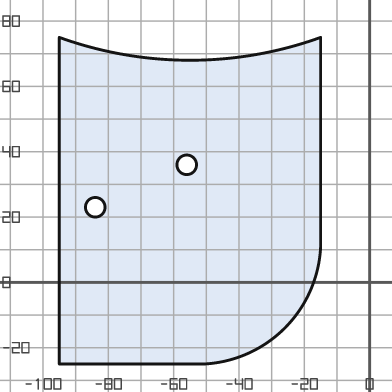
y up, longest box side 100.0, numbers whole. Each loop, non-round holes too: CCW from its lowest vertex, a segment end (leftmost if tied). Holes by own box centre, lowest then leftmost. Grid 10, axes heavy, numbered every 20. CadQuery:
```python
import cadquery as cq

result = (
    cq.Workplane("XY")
    .moveTo(-95.0, -25.0)
    .lineTo(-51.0, -25.0)
    .threePointArc((-26.0, -14.0), (-15.0, 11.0))
    .lineTo(-15.0, 75.0)
    .threePointArc((-55.0, 68.0), (-95.0, 75.0))
    .close()
    .moveTo(-84.0, 23.0)
    .circle(3.0)
    .moveTo(-56.0, 36.0)
    .circle(3.0)
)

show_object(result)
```